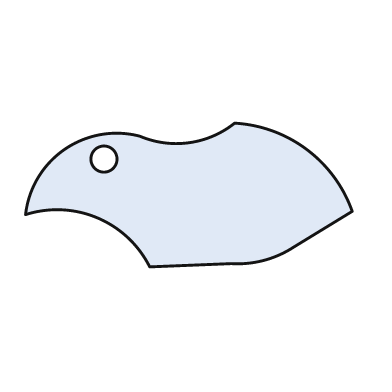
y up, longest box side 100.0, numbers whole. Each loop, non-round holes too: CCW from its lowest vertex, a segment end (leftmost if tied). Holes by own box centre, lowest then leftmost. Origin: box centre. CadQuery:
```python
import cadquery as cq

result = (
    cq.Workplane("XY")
    .moveTo(-12.0, -22.0)
    .lineTo(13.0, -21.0)
    .threePointArc((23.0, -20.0), (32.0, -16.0))
    .lineTo(50.0, -5.0)
    .threePointArc((36.0, 14.0), (14.0, 22.0))
    .threePointArc((0.0, 16.0), (-15.0, 18.0))
    .threePointArc((-38.0, 14.0), (-50.0, -6.0))
    .threePointArc((-28.0, -7.0), (-12.0, -22.0))
    .close()
    .moveTo(-26.0, 11.0)
    .circle(4.0)
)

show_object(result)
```